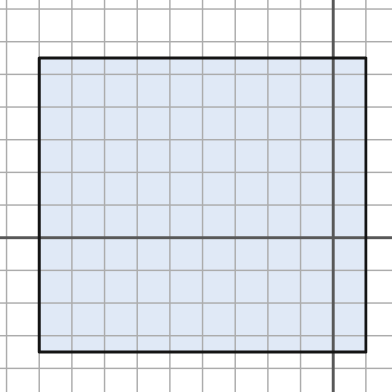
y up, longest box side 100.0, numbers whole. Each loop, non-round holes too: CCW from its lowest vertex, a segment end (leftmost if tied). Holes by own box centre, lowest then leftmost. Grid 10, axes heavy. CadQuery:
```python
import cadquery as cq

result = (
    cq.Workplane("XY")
    .moveTo(-90.0, -35.0)
    .lineTo(10.0, -35.0)
    .lineTo(10.0, 55.0)
    .lineTo(-90.0, 55.0)
    .close()
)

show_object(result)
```